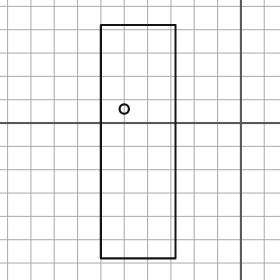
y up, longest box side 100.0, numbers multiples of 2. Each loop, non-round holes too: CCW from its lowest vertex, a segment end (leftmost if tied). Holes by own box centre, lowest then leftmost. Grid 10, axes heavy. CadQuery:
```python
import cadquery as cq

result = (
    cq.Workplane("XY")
    .moveTo(-60.0, -58.0)
    .lineTo(-28.0, -58.0)
    .lineTo(-28.0, 42.0)
    .lineTo(-60.0, 42.0)
    .close()
    .moveTo(-50.0, 6.0)
    .circle(2.0)
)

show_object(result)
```